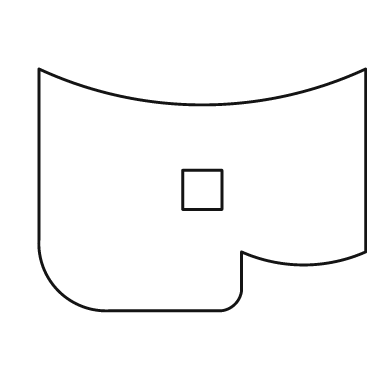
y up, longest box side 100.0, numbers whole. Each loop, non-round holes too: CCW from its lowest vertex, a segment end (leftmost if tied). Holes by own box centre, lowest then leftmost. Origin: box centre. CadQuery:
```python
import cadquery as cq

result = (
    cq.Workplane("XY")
    .moveTo(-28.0, -37.0)
    .lineTo(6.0, -37.0)
    .threePointArc((10.0, -35.0), (12.0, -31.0))
    .lineTo(12.0, -19.0)
    .threePointArc((31.0, -23.0), (50.0, -19.0))
    .lineTo(50.0, 37.0)
    .threePointArc((0.0, 26.0), (-50.0, 37.0))
    .lineTo(-50.0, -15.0)
    .threePointArc((-44.0, -31.0), (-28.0, -37.0))
    .close()
    .moveTo(-6.0, -6.0)
    .lineTo(6.0, -6.0)
    .lineTo(6.0, 6.0)
    .lineTo(-6.0, 6.0)
    .close()
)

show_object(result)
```